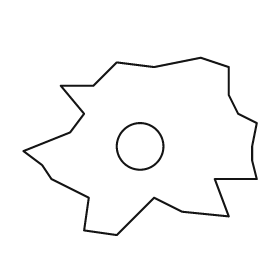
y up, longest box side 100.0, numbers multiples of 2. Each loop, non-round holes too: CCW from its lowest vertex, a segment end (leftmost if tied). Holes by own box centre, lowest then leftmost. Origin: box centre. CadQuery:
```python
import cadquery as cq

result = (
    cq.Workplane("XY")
    .moveTo(-10.0, -38.0)
    .lineTo(6.0, -22.0)
    .lineTo(18.0, -28.0)
    .lineTo(38.0, -30.0)
    .lineTo(32.0, -14.0)
    .lineTo(50.0, -14.0)
    .lineTo(48.0, -6.0)
    .lineTo(48.0, 0.0)
    .lineTo(50.0, 10.0)
    .lineTo(42.0, 14.0)
    .lineTo(38.0, 22.0)
    .lineTo(38.0, 34.0)
    .lineTo(26.0, 38.0)
    .lineTo(6.0, 34.0)
    .lineTo(-10.0, 36.0)
    .lineTo(-20.0, 26.0)
    .lineTo(-34.0, 26.0)
    .lineTo(-24.0, 14.0)
    .lineTo(-30.0, 6.0)
    .lineTo(-50.0, -2.0)
    .lineTo(-42.0, -8.0)
    .lineTo(-38.0, -14.0)
    .lineTo(-22.0, -22.0)
    .lineTo(-24.0, -36.0)
    .close()
    .moveTo(0.0, 0.0)
    .circle(10.0)
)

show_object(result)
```